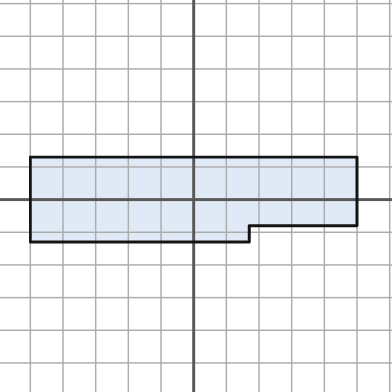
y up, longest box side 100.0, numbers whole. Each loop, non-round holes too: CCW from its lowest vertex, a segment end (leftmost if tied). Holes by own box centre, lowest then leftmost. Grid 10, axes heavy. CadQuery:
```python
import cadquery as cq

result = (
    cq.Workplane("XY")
    .moveTo(-50.0, -13.0)
    .lineTo(17.0, -13.0)
    .lineTo(17.0, -8.0)
    .lineTo(50.0, -8.0)
    .lineTo(50.0, 13.0)
    .lineTo(-50.0, 13.0)
    .close()
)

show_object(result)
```